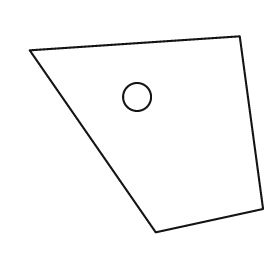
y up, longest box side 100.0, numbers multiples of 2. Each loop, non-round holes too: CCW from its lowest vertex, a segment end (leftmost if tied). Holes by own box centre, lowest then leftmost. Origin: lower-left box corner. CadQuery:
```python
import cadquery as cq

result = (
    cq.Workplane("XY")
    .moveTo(54.0, 0.0)
    .lineTo(100.0, 10.0)
    .lineTo(90.0, 84.0)
    .lineTo(0.0, 78.0)
    .close()
    .moveTo(46.0, 58.0)
    .circle(6.0)
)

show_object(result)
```